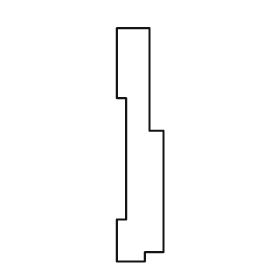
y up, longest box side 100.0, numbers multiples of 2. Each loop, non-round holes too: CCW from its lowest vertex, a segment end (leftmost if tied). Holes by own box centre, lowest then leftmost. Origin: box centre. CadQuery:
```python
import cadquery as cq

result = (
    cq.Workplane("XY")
    .moveTo(-10.0, -50.0)
    .lineTo(2.0, -50.0)
    .lineTo(2.0, -46.0)
    .lineTo(10.0, -46.0)
    .lineTo(10.0, 6.0)
    .lineTo(4.0, 6.0)
    .lineTo(4.0, 50.0)
    .lineTo(-10.0, 50.0)
    .lineTo(-10.0, 20.0)
    .lineTo(-6.0, 20.0)
    .lineTo(-6.0, -32.0)
    .lineTo(-10.0, -32.0)
    .close()
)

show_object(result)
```